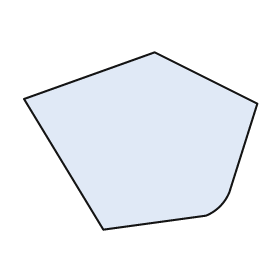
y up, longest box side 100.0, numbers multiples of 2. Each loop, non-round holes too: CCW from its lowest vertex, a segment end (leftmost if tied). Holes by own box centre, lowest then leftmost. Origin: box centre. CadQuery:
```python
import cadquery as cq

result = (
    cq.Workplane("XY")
    .moveTo(-16.0, -38.0)
    .lineTo(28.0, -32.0)
    .threePointArc((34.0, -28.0), (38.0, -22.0))
    .lineTo(50.0, 16.0)
    .lineTo(6.0, 38.0)
    .lineTo(-50.0, 18.0)
    .close()
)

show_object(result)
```